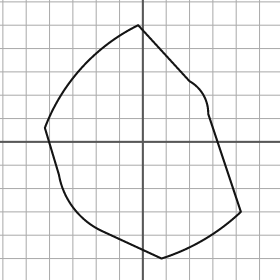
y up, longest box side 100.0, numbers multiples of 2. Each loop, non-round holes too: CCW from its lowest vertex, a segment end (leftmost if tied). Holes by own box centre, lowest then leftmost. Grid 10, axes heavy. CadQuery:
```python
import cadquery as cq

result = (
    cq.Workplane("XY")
    .moveTo(8.0, -50.0)
    .threePointArc((26.0, -42.0), (42.0, -30.0))
    .lineTo(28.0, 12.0)
    .threePointArc((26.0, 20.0), (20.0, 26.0))
    .lineTo(-2.0, 50.0)
    .threePointArc((-26.0, 32.0), (-42.0, 6.0))
    .lineTo(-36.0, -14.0)
    .threePointArc((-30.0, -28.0), (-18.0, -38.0))
    .close()
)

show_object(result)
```